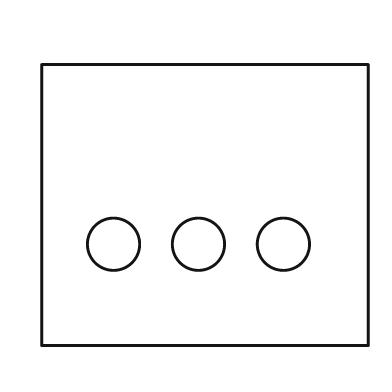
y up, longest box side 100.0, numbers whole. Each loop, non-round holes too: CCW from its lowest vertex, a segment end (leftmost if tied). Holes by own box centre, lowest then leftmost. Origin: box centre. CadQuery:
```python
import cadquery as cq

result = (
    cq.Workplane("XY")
    .moveTo(-50.0, -43.0)
    .lineTo(50.0, -43.0)
    .lineTo(50.0, 43.0)
    .lineTo(-50.0, 43.0)
    .close()
    .moveTo(-28.0, -12.0)
    .circle(8.0)
    .moveTo(-2.0, -12.0)
    .circle(8.0)
    .moveTo(24.0, -12.0)
    .circle(8.0)
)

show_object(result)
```